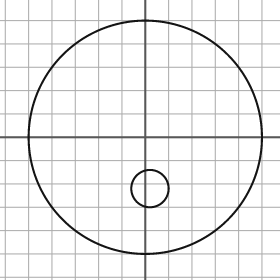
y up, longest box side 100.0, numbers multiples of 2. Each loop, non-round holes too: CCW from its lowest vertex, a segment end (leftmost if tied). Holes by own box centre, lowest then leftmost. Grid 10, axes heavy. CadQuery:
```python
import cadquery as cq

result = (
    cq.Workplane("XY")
    .moveTo(0.0, 0.0)
    .circle(50.0)
    .moveTo(2.0, -22.0)
    .circle(8.0)
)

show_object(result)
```